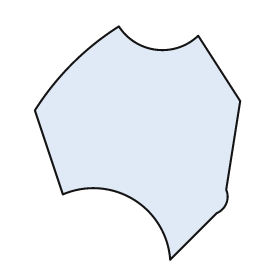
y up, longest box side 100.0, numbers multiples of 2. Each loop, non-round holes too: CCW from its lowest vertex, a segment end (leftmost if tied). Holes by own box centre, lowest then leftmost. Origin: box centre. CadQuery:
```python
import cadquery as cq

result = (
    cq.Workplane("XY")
    .moveTo(14.0, -50.0)
    .lineTo(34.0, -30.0)
    .threePointArc((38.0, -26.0), (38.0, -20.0))
    .lineTo(44.0, 18.0)
    .lineTo(26.0, 46.0)
    .threePointArc((8.0, 40.0), (-8.0, 50.0))
    .threePointArc((-28.0, 34.0), (-44.0, 14.0))
    .lineTo(-32.0, -22.0)
    .threePointArc((-2.0, -24.0), (14.0, -50.0))
    .close()
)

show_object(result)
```